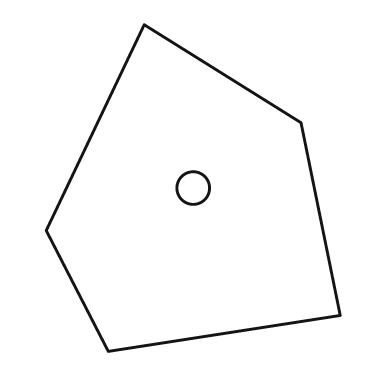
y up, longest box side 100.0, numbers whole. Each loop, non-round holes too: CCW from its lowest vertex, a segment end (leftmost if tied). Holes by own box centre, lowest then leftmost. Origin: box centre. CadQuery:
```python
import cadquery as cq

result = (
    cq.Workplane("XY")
    .moveTo(-26.0, -50.0)
    .lineTo(45.0, -39.0)
    .lineTo(33.0, 20.0)
    .lineTo(-15.0, 50.0)
    .lineTo(-45.0, -13.0)
    .close()
    .moveTo(0.0, 0.0)
    .circle(5.0)
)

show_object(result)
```